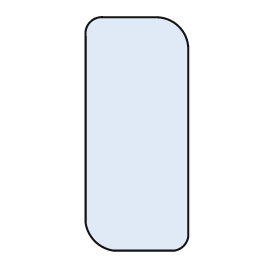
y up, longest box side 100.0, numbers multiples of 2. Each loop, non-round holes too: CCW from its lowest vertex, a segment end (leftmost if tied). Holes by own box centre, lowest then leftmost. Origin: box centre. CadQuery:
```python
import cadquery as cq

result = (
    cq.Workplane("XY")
    .moveTo(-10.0, -50.0)
    .lineTo(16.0, -50.0)
    .threePointArc((20.0, -48.0), (22.0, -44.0))
    .lineTo(22.0, 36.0)
    .threePointArc((18.0, 46.0), (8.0, 50.0))
    .lineTo(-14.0, 50.0)
    .threePointArc((-20.0, 48.0), (-22.0, 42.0))
    .lineTo(-22.0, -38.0)
    .threePointArc((-18.0, -46.0), (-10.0, -50.0))
    .close()
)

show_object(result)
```